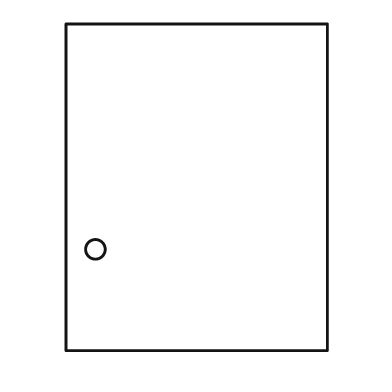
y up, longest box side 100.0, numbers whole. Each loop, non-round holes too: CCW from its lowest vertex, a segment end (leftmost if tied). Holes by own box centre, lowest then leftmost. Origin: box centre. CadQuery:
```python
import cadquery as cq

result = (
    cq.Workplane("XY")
    .moveTo(-40.0, -50.0)
    .lineTo(40.0, -50.0)
    .lineTo(40.0, 50.0)
    .lineTo(-40.0, 50.0)
    .close()
    .moveTo(-31.0, -19.0)
    .circle(3.0)
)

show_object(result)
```